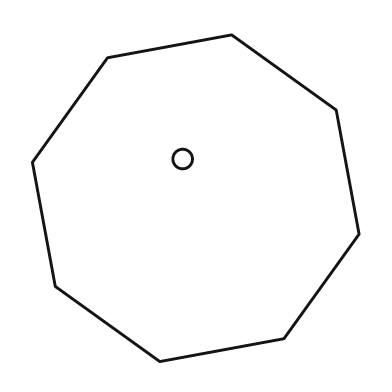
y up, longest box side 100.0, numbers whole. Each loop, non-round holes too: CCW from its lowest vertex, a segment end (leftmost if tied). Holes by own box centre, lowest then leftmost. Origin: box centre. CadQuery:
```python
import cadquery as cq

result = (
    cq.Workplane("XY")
    .moveTo(-11.0, -50.0)
    .lineTo(27.0, -43.0)
    .lineTo(50.0, -11.0)
    .lineTo(43.0, 27.0)
    .lineTo(11.0, 50.0)
    .lineTo(-27.0, 43.0)
    .lineTo(-50.0, 11.0)
    .lineTo(-43.0, -27.0)
    .close()
    .moveTo(-4.0, 12.0)
    .circle(3.0)
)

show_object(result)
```